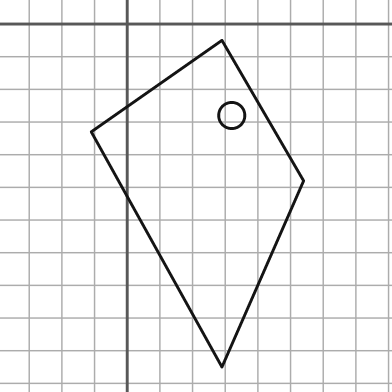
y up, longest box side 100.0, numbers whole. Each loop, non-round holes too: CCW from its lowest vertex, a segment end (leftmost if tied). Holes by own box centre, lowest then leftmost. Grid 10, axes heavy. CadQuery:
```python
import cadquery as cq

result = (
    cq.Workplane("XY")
    .moveTo(29.0, -105.0)
    .lineTo(54.0, -48.0)
    .lineTo(29.0, -5.0)
    .lineTo(-11.0, -33.0)
    .close()
    .moveTo(32.0, -28.0)
    .circle(4.0)
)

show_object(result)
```